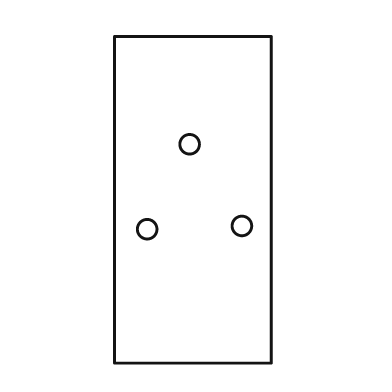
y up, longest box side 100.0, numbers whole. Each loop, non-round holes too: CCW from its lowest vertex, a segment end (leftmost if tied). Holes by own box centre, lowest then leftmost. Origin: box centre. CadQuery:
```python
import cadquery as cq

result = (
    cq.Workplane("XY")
    .moveTo(-24.0, -50.0)
    .lineTo(24.0, -50.0)
    .lineTo(24.0, 50.0)
    .lineTo(-24.0, 50.0)
    .close()
    .moveTo(-14.0, -9.0)
    .circle(3.0)
    .moveTo(15.0, -8.0)
    .circle(3.0)
    .moveTo(-1.0, 17.0)
    .circle(3.0)
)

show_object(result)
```